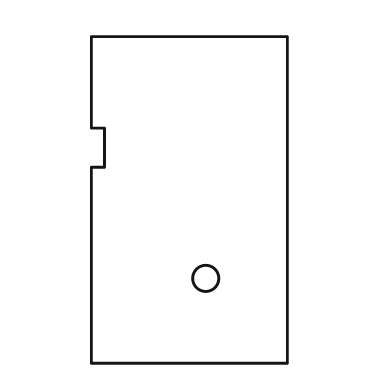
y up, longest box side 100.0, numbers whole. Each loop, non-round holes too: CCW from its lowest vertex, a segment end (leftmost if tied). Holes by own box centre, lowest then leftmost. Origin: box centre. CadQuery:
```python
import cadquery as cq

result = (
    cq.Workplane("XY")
    .moveTo(-30.0, -50.0)
    .lineTo(30.0, -50.0)
    .lineTo(30.0, 50.0)
    .lineTo(-30.0, 50.0)
    .lineTo(-30.0, 22.0)
    .lineTo(-26.0, 22.0)
    .lineTo(-26.0, 10.0)
    .lineTo(-30.0, 10.0)
    .close()
    .moveTo(5.0, -24.0)
    .circle(4.0)
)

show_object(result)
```